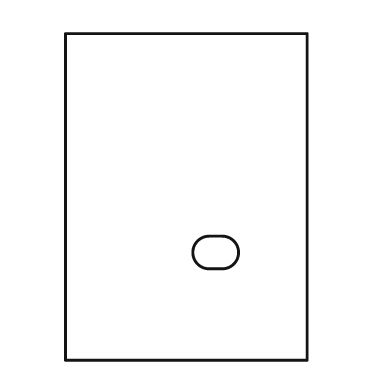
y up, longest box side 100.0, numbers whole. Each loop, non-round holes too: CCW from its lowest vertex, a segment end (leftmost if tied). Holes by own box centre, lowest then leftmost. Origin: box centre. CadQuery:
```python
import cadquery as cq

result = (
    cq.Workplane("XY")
    .moveTo(-37.0, -50.0)
    .lineTo(37.0, -50.0)
    .lineTo(37.0, 50.0)
    .lineTo(-37.0, 50.0)
    .close()
    .moveTo(7.0, -22.0)
    .lineTo(11.0, -22.0)
    .threePointArc((16.0, -17.0), (11.0, -12.0))
    .lineTo(7.0, -12.0)
    .threePointArc((2.0, -17.0), (7.0, -22.0))
    .close()
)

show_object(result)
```